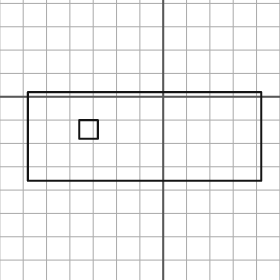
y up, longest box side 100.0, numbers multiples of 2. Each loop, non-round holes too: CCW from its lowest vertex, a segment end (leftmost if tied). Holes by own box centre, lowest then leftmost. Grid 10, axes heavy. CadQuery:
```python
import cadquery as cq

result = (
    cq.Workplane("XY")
    .moveTo(-58.0, -36.0)
    .lineTo(42.0, -36.0)
    .lineTo(42.0, 2.0)
    .lineTo(-58.0, 2.0)
    .close()
    .moveTo(-36.0, -18.0)
    .lineTo(-28.0, -18.0)
    .lineTo(-28.0, -10.0)
    .lineTo(-36.0, -10.0)
    .close()
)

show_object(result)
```